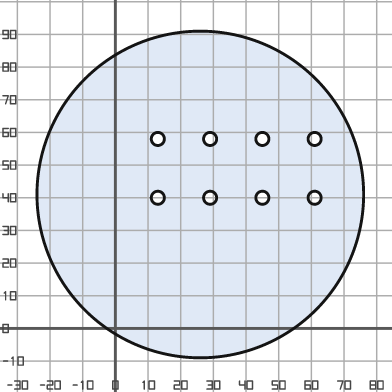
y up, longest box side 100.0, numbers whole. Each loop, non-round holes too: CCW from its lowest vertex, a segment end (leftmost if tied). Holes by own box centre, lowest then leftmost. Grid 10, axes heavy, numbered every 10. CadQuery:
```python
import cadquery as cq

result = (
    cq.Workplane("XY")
    .moveTo(26.0, 41.0)
    .circle(50.0)
    .moveTo(13.0, 40.0)
    .circle(2.0)
    .moveTo(29.0, 40.0)
    .circle(2.0)
    .moveTo(45.0, 40.0)
    .circle(2.0)
    .moveTo(61.0, 40.0)
    .circle(2.0)
    .moveTo(13.0, 58.0)
    .circle(2.0)
    .moveTo(29.0, 58.0)
    .circle(2.0)
    .moveTo(45.0, 58.0)
    .circle(2.0)
    .moveTo(61.0, 58.0)
    .circle(2.0)
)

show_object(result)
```